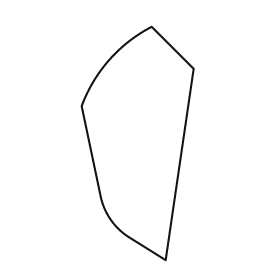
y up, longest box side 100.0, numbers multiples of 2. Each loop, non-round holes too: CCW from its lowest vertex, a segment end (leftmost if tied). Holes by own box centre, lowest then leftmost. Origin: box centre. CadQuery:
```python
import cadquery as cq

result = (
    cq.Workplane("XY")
    .moveTo(12.0, -50.0)
    .lineTo(24.0, 32.0)
    .lineTo(6.0, 50.0)
    .threePointArc((-12.0, 36.0), (-24.0, 16.0))
    .lineTo(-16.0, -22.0)
    .threePointArc((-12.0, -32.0), (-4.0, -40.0))
    .close()
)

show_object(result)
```